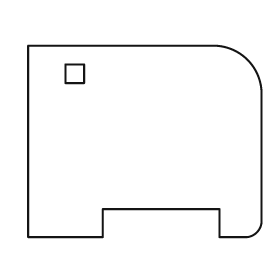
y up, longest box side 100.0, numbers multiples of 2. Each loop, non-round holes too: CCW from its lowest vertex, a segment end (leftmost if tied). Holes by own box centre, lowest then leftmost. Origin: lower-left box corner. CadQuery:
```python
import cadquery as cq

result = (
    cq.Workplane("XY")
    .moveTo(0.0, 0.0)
    .lineTo(32.0, 0.0)
    .lineTo(32.0, 12.0)
    .lineTo(82.0, 12.0)
    .lineTo(82.0, 0.0)
    .lineTo(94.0, 0.0)
    .threePointArc((98.0, 2.0), (100.0, 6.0))
    .lineTo(100.0, 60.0)
    .threePointArc((94.0, 76.0), (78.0, 82.0))
    .lineTo(0.0, 82.0)
    .close()
    .moveTo(16.0, 66.0)
    .lineTo(24.0, 66.0)
    .lineTo(24.0, 74.0)
    .lineTo(16.0, 74.0)
    .close()
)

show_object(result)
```